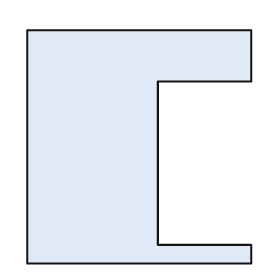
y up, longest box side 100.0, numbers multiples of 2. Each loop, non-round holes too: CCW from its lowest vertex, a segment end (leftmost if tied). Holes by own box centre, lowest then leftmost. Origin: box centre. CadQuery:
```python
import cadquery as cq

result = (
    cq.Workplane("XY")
    .moveTo(-48.0, -50.0)
    .lineTo(48.0, -50.0)
    .lineTo(48.0, -42.0)
    .lineTo(8.0, -42.0)
    .lineTo(8.0, 28.0)
    .lineTo(48.0, 28.0)
    .lineTo(48.0, 50.0)
    .lineTo(-48.0, 50.0)
    .close()
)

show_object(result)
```